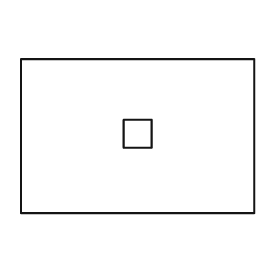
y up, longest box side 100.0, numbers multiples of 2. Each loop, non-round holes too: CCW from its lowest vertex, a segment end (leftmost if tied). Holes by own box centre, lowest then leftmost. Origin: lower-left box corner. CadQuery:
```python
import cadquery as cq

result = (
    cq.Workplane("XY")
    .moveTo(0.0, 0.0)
    .lineTo(100.0, 0.0)
    .lineTo(100.0, 66.0)
    .lineTo(0.0, 66.0)
    .close()
    .moveTo(44.0, 28.0)
    .lineTo(56.0, 28.0)
    .lineTo(56.0, 40.0)
    .lineTo(44.0, 40.0)
    .close()
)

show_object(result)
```